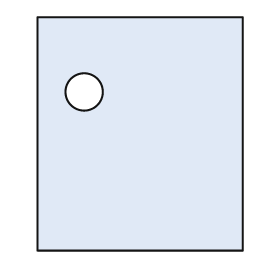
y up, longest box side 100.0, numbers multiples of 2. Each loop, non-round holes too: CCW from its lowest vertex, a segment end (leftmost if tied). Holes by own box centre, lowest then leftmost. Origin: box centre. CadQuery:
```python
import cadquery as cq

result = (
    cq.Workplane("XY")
    .moveTo(-44.0, -50.0)
    .lineTo(44.0, -50.0)
    .lineTo(44.0, 50.0)
    .lineTo(-44.0, 50.0)
    .close()
    .moveTo(-24.0, 18.0)
    .circle(8.0)
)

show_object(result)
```